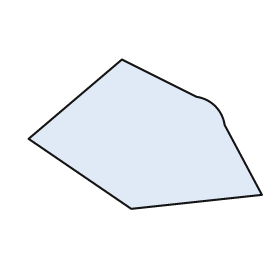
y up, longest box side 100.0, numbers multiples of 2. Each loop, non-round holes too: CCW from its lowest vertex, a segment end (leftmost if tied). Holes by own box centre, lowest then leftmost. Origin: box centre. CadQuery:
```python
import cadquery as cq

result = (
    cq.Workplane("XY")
    .moveTo(-6.0, -32.0)
    .lineTo(50.0, -26.0)
    .lineTo(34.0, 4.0)
    .threePointArc((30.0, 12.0), (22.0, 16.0))
    .lineTo(-10.0, 32.0)
    .lineTo(-50.0, -2.0)
    .close()
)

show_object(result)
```